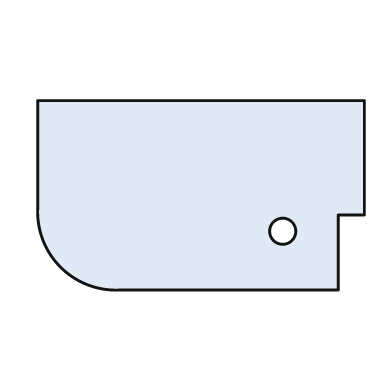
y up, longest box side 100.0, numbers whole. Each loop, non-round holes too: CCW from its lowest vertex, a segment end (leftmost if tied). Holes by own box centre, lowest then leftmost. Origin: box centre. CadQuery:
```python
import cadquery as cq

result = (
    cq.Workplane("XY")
    .moveTo(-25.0, -29.0)
    .lineTo(42.0, -29.0)
    .lineTo(42.0, -6.0)
    .lineTo(50.0, -6.0)
    .lineTo(50.0, 29.0)
    .lineTo(-50.0, 29.0)
    .lineTo(-50.0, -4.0)
    .threePointArc((-43.0, -22.0), (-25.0, -29.0))
    .close()
    .moveTo(25.0, -11.0)
    .circle(4.0)
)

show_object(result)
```